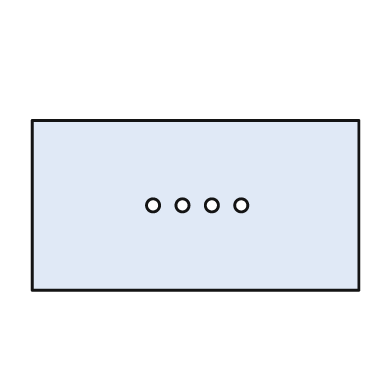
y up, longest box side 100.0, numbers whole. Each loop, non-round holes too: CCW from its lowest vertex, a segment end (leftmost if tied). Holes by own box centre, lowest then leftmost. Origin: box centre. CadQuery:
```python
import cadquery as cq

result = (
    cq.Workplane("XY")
    .moveTo(-50.0, -26.0)
    .lineTo(50.0, -26.0)
    .lineTo(50.0, 26.0)
    .lineTo(-50.0, 26.0)
    .close()
    .moveTo(-13.0, 0.0)
    .circle(2.0)
    .moveTo(-4.0, 0.0)
    .circle(2.0)
    .moveTo(5.0, 0.0)
    .circle(2.0)
    .moveTo(14.0, 0.0)
    .circle(2.0)
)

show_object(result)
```